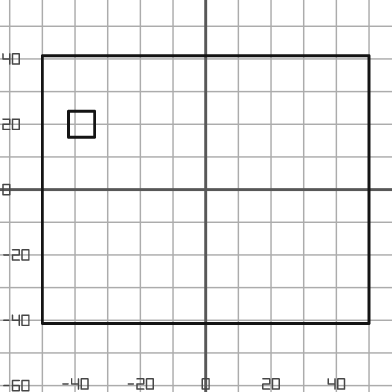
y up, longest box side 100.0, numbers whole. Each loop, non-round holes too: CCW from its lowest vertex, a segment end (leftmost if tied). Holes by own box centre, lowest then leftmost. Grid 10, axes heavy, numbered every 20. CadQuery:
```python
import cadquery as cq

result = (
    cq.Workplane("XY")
    .moveTo(-50.0, -41.0)
    .lineTo(50.0, -41.0)
    .lineTo(50.0, 41.0)
    .lineTo(-50.0, 41.0)
    .close()
    .moveTo(-42.0, 16.0)
    .lineTo(-34.0, 16.0)
    .lineTo(-34.0, 24.0)
    .lineTo(-42.0, 24.0)
    .close()
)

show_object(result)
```